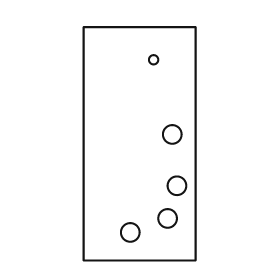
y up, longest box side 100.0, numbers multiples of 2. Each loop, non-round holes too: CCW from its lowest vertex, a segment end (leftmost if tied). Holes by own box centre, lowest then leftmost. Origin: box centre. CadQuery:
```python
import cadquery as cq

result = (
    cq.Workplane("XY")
    .moveTo(-24.0, -50.0)
    .lineTo(24.0, -50.0)
    .lineTo(24.0, 50.0)
    .lineTo(-24.0, 50.0)
    .close()
    .moveTo(-4.0, -38.0)
    .circle(4.0)
    .moveTo(12.0, -32.0)
    .circle(4.0)
    .moveTo(16.0, -18.0)
    .circle(4.0)
    .moveTo(14.0, 4.0)
    .circle(4.0)
    .moveTo(6.0, 36.0)
    .circle(2.0)
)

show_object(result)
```